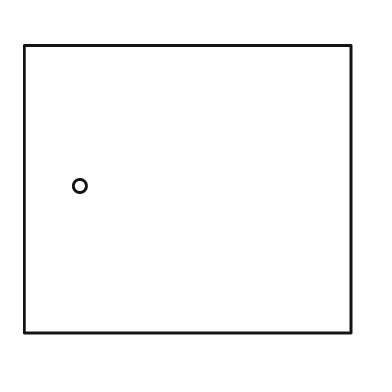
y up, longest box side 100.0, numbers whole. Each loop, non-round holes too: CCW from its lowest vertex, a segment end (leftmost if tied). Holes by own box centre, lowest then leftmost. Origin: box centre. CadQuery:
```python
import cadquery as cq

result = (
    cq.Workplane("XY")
    .moveTo(-50.0, -44.0)
    .lineTo(50.0, -44.0)
    .lineTo(50.0, 44.0)
    .lineTo(-50.0, 44.0)
    .close()
    .moveTo(-33.0, 1.0)
    .circle(2.0)
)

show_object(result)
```